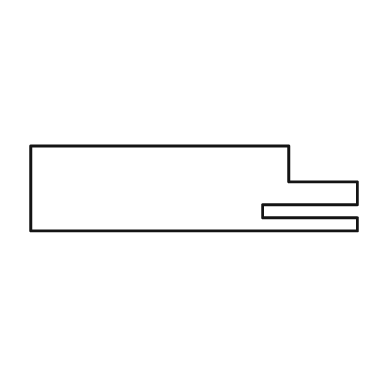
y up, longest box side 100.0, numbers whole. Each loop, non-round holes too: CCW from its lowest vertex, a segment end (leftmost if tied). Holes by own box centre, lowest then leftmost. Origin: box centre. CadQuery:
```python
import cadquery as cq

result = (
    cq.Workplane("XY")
    .moveTo(-50.0, -13.0)
    .lineTo(50.0, -13.0)
    .lineTo(50.0, -9.0)
    .lineTo(21.0, -9.0)
    .lineTo(21.0, -5.0)
    .lineTo(50.0, -5.0)
    .lineTo(50.0, 2.0)
    .lineTo(29.0, 2.0)
    .lineTo(29.0, 13.0)
    .lineTo(-50.0, 13.0)
    .close()
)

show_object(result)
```